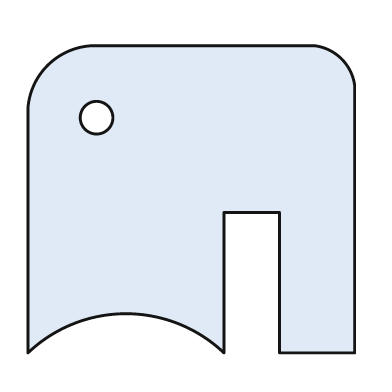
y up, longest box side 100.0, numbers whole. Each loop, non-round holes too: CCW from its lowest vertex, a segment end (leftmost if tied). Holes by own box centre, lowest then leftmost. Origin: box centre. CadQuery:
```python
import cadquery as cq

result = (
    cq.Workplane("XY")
    .moveTo(-50.0, -47.0)
    .threePointArc((-20.0, -35.0), (10.0, -47.0))
    .lineTo(10.0, -4.0)
    .lineTo(27.0, -4.0)
    .lineTo(27.0, -47.0)
    .lineTo(50.0, -47.0)
    .lineTo(50.0, 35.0)
    .threePointArc((46.0, 43.0), (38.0, 47.0))
    .lineTo(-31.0, 47.0)
    .threePointArc((-44.0, 41.0), (-50.0, 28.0))
    .close()
    .moveTo(-29.0, 25.0)
    .circle(5.0)
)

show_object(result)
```